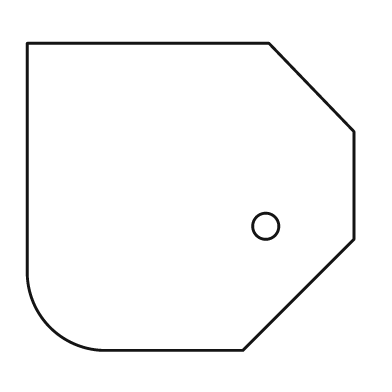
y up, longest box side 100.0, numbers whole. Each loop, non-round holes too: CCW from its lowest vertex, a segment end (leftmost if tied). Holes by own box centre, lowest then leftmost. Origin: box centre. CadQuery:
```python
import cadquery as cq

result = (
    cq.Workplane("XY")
    .moveTo(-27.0, -47.0)
    .lineTo(16.0, -47.0)
    .lineTo(50.0, -13.0)
    .lineTo(50.0, 20.0)
    .lineTo(24.0, 47.0)
    .lineTo(-50.0, 47.0)
    .lineTo(-50.0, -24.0)
    .threePointArc((-43.0, -40.0), (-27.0, -47.0))
    .close()
    .moveTo(23.0, -9.0)
    .circle(4.0)
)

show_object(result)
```